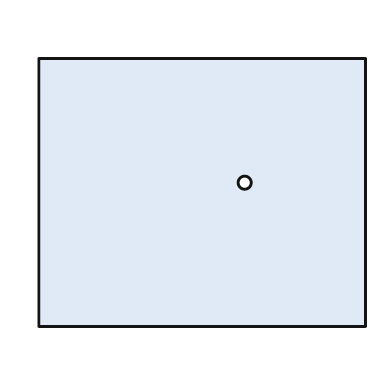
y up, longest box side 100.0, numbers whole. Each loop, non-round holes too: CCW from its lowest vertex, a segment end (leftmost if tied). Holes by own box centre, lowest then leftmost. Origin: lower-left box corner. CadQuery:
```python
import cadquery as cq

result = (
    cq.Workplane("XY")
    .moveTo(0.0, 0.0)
    .lineTo(100.0, 0.0)
    .lineTo(100.0, 82.0)
    .lineTo(0.0, 82.0)
    .close()
    .moveTo(63.0, 44.0)
    .circle(2.0)
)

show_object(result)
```